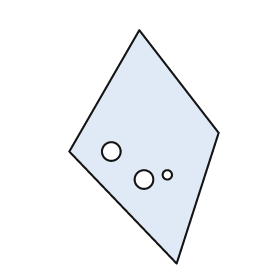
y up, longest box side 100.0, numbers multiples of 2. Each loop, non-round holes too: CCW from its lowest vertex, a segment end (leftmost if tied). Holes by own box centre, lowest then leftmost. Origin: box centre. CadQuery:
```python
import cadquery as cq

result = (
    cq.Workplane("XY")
    .moveTo(14.0, -50.0)
    .lineTo(32.0, 6.0)
    .lineTo(-2.0, 50.0)
    .lineTo(-32.0, -2.0)
    .close()
    .moveTo(0.0, -14.0)
    .circle(4.0)
    .moveTo(10.0, -12.0)
    .circle(2.0)
    .moveTo(-14.0, -2.0)
    .circle(4.0)
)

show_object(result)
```